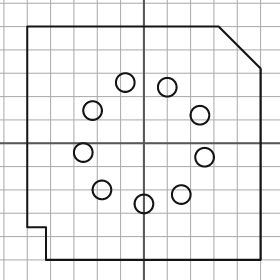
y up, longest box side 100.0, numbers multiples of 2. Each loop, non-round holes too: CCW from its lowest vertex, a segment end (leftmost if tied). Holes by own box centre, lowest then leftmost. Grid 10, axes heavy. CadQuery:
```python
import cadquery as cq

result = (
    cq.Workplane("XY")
    .moveTo(-42.0, -50.0)
    .lineTo(50.0, -50.0)
    .lineTo(50.0, 32.0)
    .lineTo(32.0, 50.0)
    .lineTo(-50.0, 50.0)
    .lineTo(-50.0, -36.0)
    .lineTo(-42.0, -36.0)
    .close()
    .moveTo(0.0, -26.0)
    .circle(4.0)
    .moveTo(16.0, -22.0)
    .circle(4.0)
    .moveTo(-18.0, -20.0)
    .circle(4.0)
    .moveTo(26.0, -6.0)
    .circle(4.0)
    .moveTo(-26.0, -4.0)
    .circle(4.0)
    .moveTo(24.0, 12.0)
    .circle(4.0)
    .moveTo(-22.0, 14.0)
    .circle(4.0)
    .moveTo(10.0, 24.0)
    .circle(4.0)
    .moveTo(-8.0, 26.0)
    .circle(4.0)
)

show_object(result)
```